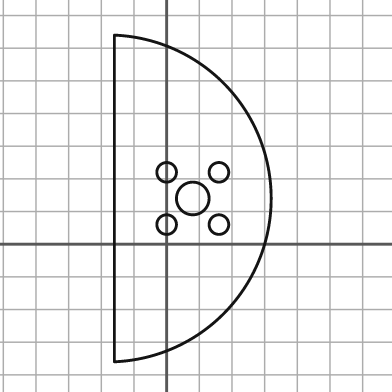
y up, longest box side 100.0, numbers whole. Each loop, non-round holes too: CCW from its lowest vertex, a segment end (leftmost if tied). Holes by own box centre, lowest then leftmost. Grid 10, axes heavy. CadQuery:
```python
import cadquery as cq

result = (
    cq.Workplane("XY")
    .moveTo(-16.0, -36.0)
    .threePointArc((32.0, 14.0), (-16.0, 64.0))
    .close()
    .moveTo(0.0, 6.0)
    .circle(3.0)
    .moveTo(16.0, 6.0)
    .circle(3.0)
    .moveTo(8.0, 14.0)
    .circle(5.0)
    .moveTo(0.0, 22.0)
    .circle(3.0)
    .moveTo(16.0, 22.0)
    .circle(3.0)
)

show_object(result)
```